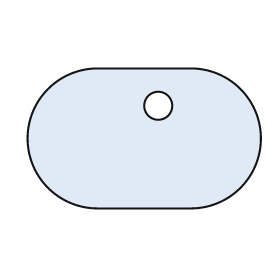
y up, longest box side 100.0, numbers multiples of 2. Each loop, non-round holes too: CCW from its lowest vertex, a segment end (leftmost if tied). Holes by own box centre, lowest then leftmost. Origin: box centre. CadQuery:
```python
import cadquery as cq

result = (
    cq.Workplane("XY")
    .moveTo(-20.0, -30.0)
    .lineTo(20.0, -30.0)
    .threePointArc((50.0, 0.0), (20.0, 30.0))
    .lineTo(-20.0, 30.0)
    .threePointArc((-50.0, 0.0), (-20.0, -30.0))
    .close()
    .moveTo(6.0, 14.0)
    .circle(6.0)
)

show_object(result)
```